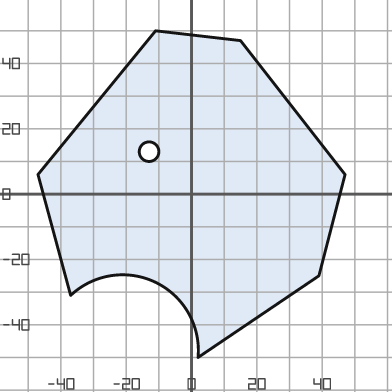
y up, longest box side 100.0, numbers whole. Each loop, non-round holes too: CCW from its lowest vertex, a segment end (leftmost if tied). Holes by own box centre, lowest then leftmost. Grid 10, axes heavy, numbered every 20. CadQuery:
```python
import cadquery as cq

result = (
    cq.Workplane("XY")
    .moveTo(2.0, -50.0)
    .lineTo(39.0, -25.0)
    .lineTo(47.0, 6.0)
    .lineTo(15.0, 47.0)
    .lineTo(-11.0, 50.0)
    .lineTo(-47.0, 6.0)
    .lineTo(-37.0, -31.0)
    .threePointArc((-11.0, -27.0), (2.0, -50.0))
    .close()
    .moveTo(-13.0, 13.0)
    .circle(3.0)
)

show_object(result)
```